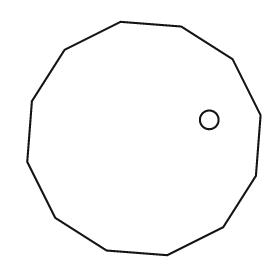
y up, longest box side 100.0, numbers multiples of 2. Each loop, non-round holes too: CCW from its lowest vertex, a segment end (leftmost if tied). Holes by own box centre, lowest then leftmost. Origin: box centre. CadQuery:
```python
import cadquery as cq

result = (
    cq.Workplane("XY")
    .moveTo(10.0, -50.0)
    .lineTo(34.0, -38.0)
    .lineTo(48.0, -16.0)
    .lineTo(50.0, 10.0)
    .lineTo(38.0, 34.0)
    .lineTo(16.0, 48.0)
    .lineTo(-10.0, 50.0)
    .lineTo(-34.0, 38.0)
    .lineTo(-48.0, 16.0)
    .lineTo(-50.0, -10.0)
    .lineTo(-38.0, -34.0)
    .lineTo(-16.0, -48.0)
    .close()
    .moveTo(28.0, 8.0)
    .circle(4.0)
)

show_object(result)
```